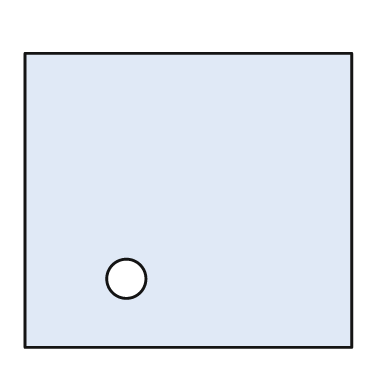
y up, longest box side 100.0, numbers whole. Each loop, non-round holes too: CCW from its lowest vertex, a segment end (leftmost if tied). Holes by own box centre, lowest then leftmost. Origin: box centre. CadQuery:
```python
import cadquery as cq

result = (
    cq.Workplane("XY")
    .moveTo(-50.0, -45.0)
    .lineTo(50.0, -45.0)
    .lineTo(50.0, 45.0)
    .lineTo(-50.0, 45.0)
    .close()
    .moveTo(-19.0, -24.0)
    .circle(6.0)
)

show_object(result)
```